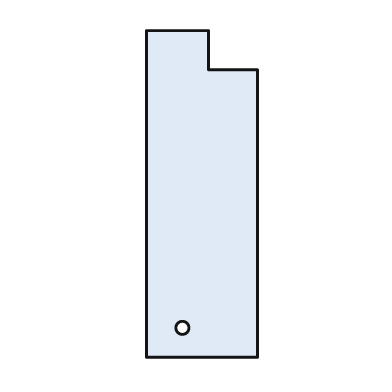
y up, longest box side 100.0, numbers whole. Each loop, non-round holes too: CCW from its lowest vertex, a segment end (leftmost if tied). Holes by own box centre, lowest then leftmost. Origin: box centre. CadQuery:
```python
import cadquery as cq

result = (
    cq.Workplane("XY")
    .moveTo(-17.0, -50.0)
    .lineTo(17.0, -50.0)
    .lineTo(17.0, 38.0)
    .lineTo(2.0, 38.0)
    .lineTo(2.0, 50.0)
    .lineTo(-17.0, 50.0)
    .close()
    .moveTo(-6.0, -41.0)
    .circle(2.0)
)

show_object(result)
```